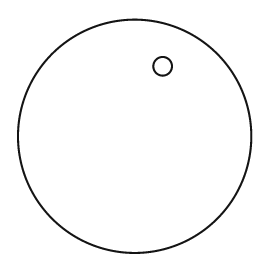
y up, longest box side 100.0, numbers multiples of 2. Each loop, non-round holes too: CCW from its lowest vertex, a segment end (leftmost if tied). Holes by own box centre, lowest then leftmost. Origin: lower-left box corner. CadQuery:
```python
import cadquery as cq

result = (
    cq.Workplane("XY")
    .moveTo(50.0, 50.0)
    .circle(50.0)
    .moveTo(62.0, 80.0)
    .circle(4.0)
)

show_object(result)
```